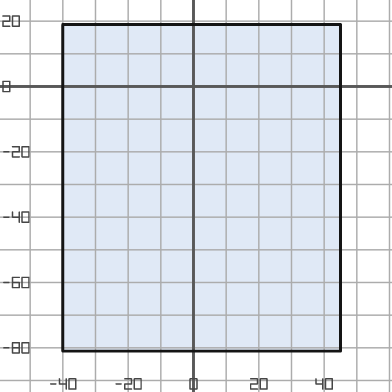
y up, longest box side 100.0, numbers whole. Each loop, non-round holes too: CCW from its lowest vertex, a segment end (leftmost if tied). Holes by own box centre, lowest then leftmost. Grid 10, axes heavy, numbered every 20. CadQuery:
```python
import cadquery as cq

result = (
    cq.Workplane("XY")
    .moveTo(-40.0, -81.0)
    .lineTo(45.0, -81.0)
    .lineTo(45.0, 19.0)
    .lineTo(-40.0, 19.0)
    .close()
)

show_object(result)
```